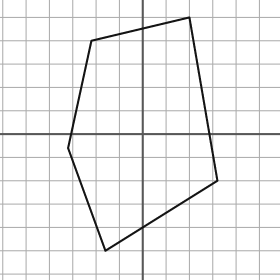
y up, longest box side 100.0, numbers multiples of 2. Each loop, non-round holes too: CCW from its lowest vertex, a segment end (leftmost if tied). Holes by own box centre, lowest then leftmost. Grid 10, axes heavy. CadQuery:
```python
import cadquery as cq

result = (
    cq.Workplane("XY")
    .moveTo(-16.0, -50.0)
    .lineTo(32.0, -20.0)
    .lineTo(20.0, 50.0)
    .lineTo(-22.0, 40.0)
    .lineTo(-32.0, -6.0)
    .close()
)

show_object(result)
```